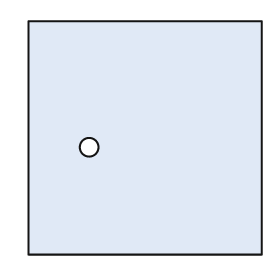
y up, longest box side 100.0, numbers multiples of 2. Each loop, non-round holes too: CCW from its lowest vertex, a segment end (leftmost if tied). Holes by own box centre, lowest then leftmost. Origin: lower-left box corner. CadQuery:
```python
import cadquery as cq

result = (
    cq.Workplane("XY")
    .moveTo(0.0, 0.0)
    .lineTo(100.0, 0.0)
    .lineTo(100.0, 100.0)
    .lineTo(0.0, 100.0)
    .close()
    .moveTo(26.0, 46.0)
    .circle(4.0)
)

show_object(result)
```